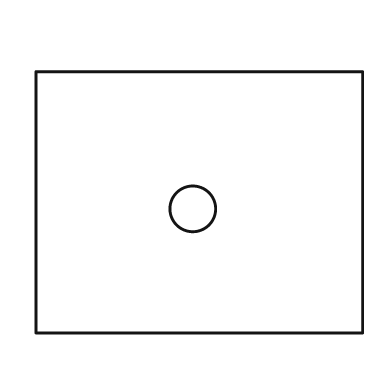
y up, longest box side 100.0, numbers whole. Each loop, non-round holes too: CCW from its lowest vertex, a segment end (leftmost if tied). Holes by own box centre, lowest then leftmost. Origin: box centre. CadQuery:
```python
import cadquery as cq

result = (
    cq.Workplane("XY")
    .moveTo(-50.0, -40.0)
    .lineTo(50.0, -40.0)
    .lineTo(50.0, 40.0)
    .lineTo(-50.0, 40.0)
    .close()
    .moveTo(-2.0, -2.0)
    .circle(7.0)
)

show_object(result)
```